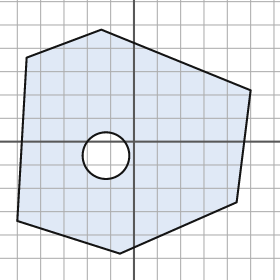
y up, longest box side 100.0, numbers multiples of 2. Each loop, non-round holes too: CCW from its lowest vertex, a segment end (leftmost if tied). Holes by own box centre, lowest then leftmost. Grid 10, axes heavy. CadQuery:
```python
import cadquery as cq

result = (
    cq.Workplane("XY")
    .moveTo(-6.0, -48.0)
    .lineTo(44.0, -26.0)
    .lineTo(50.0, 22.0)
    .lineTo(-14.0, 48.0)
    .lineTo(-46.0, 36.0)
    .lineTo(-50.0, -34.0)
    .close()
    .moveTo(-12.0, -6.0)
    .circle(10.0)
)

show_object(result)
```